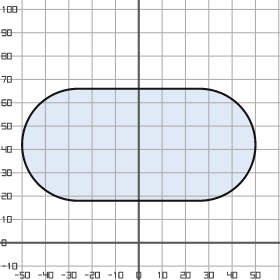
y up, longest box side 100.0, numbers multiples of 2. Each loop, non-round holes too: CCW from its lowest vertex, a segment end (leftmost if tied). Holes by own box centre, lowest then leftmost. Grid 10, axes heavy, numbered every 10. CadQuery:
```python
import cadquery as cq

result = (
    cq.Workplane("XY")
    .moveTo(-26.0, 18.0)
    .lineTo(26.0, 18.0)
    .threePointArc((50.0, 42.0), (26.0, 66.0))
    .lineTo(-26.0, 66.0)
    .threePointArc((-50.0, 42.0), (-26.0, 18.0))
    .close()
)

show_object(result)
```